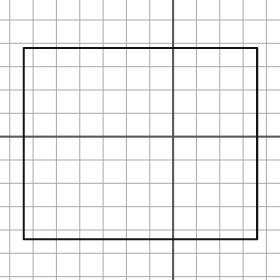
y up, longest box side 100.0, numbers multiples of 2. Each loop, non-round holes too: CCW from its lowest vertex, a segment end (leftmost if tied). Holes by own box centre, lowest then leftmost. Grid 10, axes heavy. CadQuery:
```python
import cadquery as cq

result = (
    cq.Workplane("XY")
    .moveTo(-64.0, -44.0)
    .lineTo(36.0, -44.0)
    .lineTo(36.0, 38.0)
    .lineTo(-64.0, 38.0)
    .close()
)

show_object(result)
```